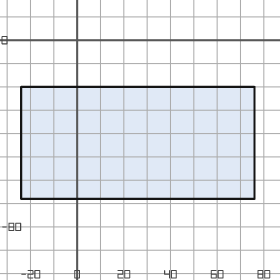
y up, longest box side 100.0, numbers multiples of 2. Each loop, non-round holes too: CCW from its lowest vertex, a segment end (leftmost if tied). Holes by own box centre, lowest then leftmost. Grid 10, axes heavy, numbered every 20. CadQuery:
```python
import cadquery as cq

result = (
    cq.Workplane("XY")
    .moveTo(-24.0, -68.0)
    .lineTo(76.0, -68.0)
    .lineTo(76.0, -20.0)
    .lineTo(-24.0, -20.0)
    .close()
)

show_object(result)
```